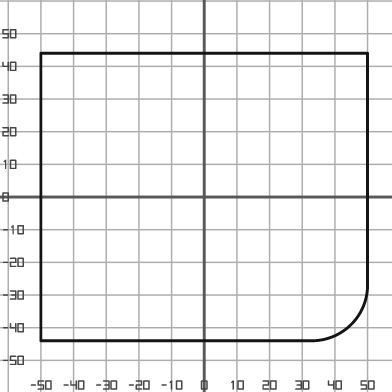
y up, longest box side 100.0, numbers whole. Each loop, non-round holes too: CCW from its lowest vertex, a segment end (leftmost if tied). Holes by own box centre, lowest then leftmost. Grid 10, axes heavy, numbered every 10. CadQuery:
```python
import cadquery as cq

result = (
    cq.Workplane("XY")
    .moveTo(-50.0, -44.0)
    .lineTo(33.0, -44.0)
    .threePointArc((45.0, -39.0), (50.0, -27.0))
    .lineTo(50.0, 44.0)
    .lineTo(-50.0, 44.0)
    .close()
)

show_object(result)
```